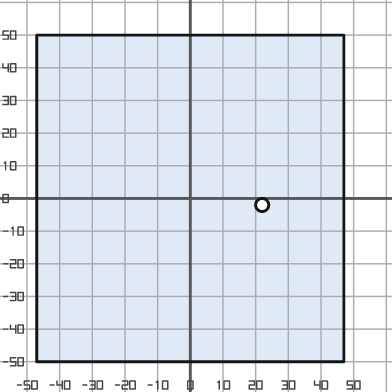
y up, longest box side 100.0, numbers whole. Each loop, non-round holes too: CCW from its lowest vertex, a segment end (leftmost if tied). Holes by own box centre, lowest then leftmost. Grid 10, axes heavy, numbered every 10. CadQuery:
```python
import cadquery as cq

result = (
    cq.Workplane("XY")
    .moveTo(-47.0, -50.0)
    .lineTo(47.0, -50.0)
    .lineTo(47.0, 50.0)
    .lineTo(-47.0, 50.0)
    .close()
    .moveTo(22.0, -2.0)
    .circle(2.0)
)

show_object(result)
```